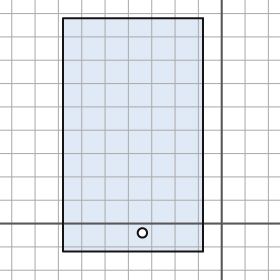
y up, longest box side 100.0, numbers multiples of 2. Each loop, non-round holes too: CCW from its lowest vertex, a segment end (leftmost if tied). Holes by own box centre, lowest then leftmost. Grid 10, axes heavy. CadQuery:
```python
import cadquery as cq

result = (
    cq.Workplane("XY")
    .moveTo(-68.0, -12.0)
    .lineTo(-8.0, -12.0)
    .lineTo(-8.0, 88.0)
    .lineTo(-68.0, 88.0)
    .close()
    .moveTo(-34.0, -4.0)
    .circle(2.0)
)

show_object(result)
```